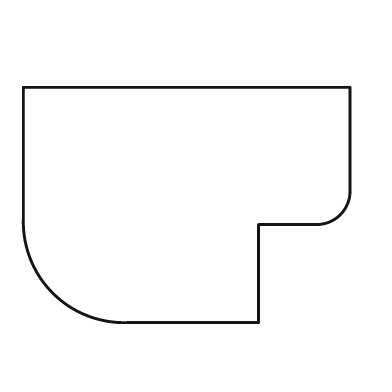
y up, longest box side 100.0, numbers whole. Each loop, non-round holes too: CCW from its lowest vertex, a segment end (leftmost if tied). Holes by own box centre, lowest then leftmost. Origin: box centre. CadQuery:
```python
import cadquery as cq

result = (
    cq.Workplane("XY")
    .moveTo(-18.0, -36.0)
    .lineTo(22.0, -36.0)
    .lineTo(22.0, -6.0)
    .lineTo(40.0, -6.0)
    .threePointArc((47.0, -3.0), (50.0, 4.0))
    .lineTo(50.0, 36.0)
    .lineTo(-50.0, 36.0)
    .lineTo(-50.0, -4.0)
    .threePointArc((-41.0, -27.0), (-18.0, -36.0))
    .close()
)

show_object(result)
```